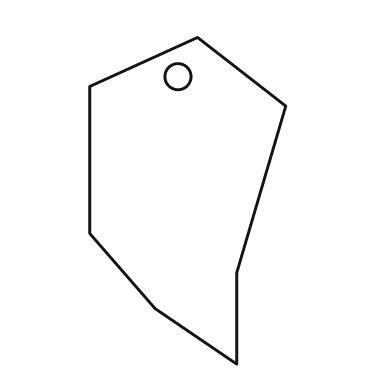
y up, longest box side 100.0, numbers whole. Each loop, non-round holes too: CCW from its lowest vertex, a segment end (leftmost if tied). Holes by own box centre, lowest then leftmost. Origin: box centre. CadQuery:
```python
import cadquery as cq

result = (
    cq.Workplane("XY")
    .moveTo(15.0, -50.0)
    .lineTo(15.0, -22.0)
    .lineTo(30.0, 29.0)
    .lineTo(3.0, 50.0)
    .lineTo(-30.0, 35.0)
    .lineTo(-30.0, -10.0)
    .lineTo(-10.0, -33.0)
    .close()
    .moveTo(-3.0, 38.0)
    .circle(4.0)
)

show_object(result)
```